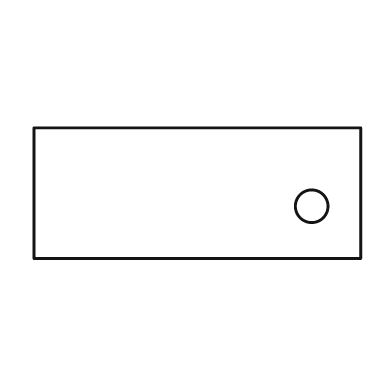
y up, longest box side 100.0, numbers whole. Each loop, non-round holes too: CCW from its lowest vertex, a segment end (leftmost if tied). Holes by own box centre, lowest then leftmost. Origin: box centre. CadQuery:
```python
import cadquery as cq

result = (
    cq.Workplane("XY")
    .moveTo(-50.0, -20.0)
    .lineTo(50.0, -20.0)
    .lineTo(50.0, 20.0)
    .lineTo(-50.0, 20.0)
    .close()
    .moveTo(35.0, -4.0)
    .circle(5.0)
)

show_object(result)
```